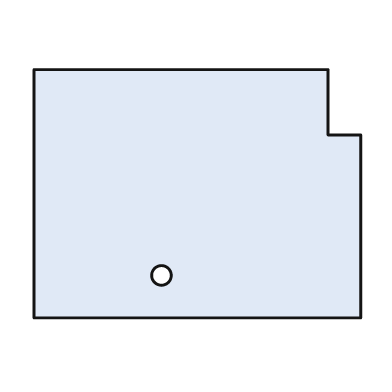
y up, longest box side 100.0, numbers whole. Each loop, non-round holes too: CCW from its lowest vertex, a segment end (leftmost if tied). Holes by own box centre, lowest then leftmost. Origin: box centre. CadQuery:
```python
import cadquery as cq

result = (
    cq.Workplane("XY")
    .moveTo(-50.0, -38.0)
    .lineTo(50.0, -38.0)
    .lineTo(50.0, 18.0)
    .lineTo(40.0, 18.0)
    .lineTo(40.0, 38.0)
    .lineTo(-50.0, 38.0)
    .close()
    .moveTo(-11.0, -25.0)
    .circle(3.0)
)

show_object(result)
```